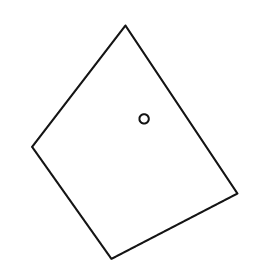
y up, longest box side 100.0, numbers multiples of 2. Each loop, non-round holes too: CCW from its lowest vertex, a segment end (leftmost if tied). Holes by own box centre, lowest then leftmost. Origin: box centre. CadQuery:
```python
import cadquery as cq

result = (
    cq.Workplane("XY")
    .moveTo(-10.0, -50.0)
    .lineTo(44.0, -22.0)
    .lineTo(-4.0, 50.0)
    .lineTo(-44.0, -2.0)
    .close()
    .moveTo(4.0, 10.0)
    .circle(2.0)
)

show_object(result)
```